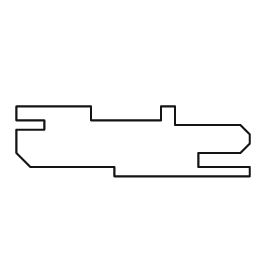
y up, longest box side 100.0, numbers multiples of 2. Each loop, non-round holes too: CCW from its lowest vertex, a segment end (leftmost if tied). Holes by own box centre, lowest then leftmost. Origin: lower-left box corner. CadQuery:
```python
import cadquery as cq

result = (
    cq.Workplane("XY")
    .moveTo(42.0, 0.0)
    .lineTo(100.0, 0.0)
    .lineTo(100.0, 4.0)
    .lineTo(78.0, 4.0)
    .lineTo(78.0, 10.0)
    .lineTo(96.0, 10.0)
    .lineTo(100.0, 14.0)
    .lineTo(100.0, 18.0)
    .lineTo(96.0, 22.0)
    .lineTo(68.0, 22.0)
    .lineTo(68.0, 30.0)
    .lineTo(62.0, 30.0)
    .lineTo(62.0, 24.0)
    .lineTo(32.0, 24.0)
    .lineTo(32.0, 30.0)
    .lineTo(0.0, 30.0)
    .lineTo(0.0, 24.0)
    .lineTo(12.0, 24.0)
    .lineTo(12.0, 20.0)
    .lineTo(0.0, 20.0)
    .lineTo(0.0, 10.0)
    .lineTo(6.0, 4.0)
    .lineTo(42.0, 4.0)
    .close()
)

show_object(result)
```